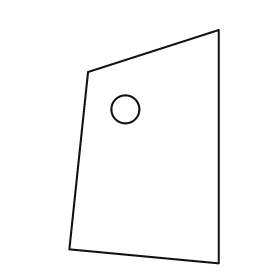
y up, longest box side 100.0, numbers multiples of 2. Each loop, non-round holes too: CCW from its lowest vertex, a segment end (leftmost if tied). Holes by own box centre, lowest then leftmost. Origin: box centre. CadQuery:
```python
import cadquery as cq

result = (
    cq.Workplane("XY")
    .moveTo(32.0, -50.0)
    .lineTo(32.0, 50.0)
    .lineTo(-24.0, 32.0)
    .lineTo(-32.0, -44.0)
    .close()
    .moveTo(-8.0, 16.0)
    .circle(6.0)
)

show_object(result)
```